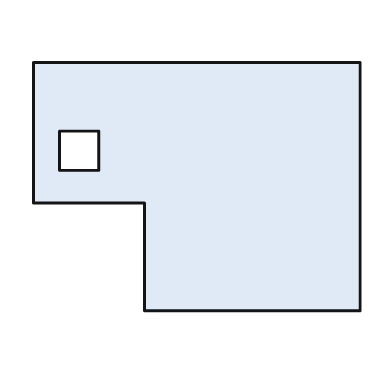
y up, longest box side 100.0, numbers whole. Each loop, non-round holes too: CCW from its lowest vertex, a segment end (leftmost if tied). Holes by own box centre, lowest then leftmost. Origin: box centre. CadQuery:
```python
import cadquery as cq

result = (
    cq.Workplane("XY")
    .moveTo(-16.0, -38.0)
    .lineTo(50.0, -38.0)
    .lineTo(50.0, 38.0)
    .lineTo(-50.0, 38.0)
    .lineTo(-50.0, -5.0)
    .lineTo(-16.0, -5.0)
    .close()
    .moveTo(-42.0, 5.0)
    .lineTo(-30.0, 5.0)
    .lineTo(-30.0, 17.0)
    .lineTo(-42.0, 17.0)
    .close()
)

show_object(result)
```